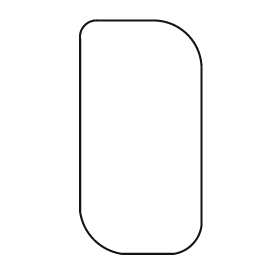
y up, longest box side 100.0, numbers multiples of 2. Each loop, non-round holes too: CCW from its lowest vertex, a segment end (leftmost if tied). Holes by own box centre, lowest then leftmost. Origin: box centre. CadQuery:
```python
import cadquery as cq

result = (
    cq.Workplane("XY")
    .moveTo(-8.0, -50.0)
    .lineTo(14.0, -50.0)
    .threePointArc((22.0, -46.0), (26.0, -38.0))
    .lineTo(26.0, 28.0)
    .threePointArc((20.0, 44.0), (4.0, 50.0))
    .lineTo(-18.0, 50.0)
    .threePointArc((-24.0, 48.0), (-26.0, 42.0))
    .lineTo(-26.0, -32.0)
    .threePointArc((-20.0, -44.0), (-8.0, -50.0))
    .close()
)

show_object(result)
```